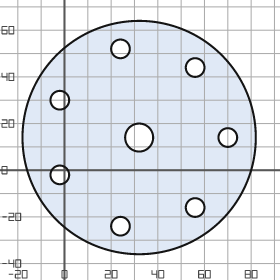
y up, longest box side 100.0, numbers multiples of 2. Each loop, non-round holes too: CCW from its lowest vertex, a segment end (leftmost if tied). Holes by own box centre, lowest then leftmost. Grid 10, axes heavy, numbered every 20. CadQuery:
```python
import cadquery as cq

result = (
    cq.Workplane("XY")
    .moveTo(32.0, 14.0)
    .circle(50.0)
    .moveTo(24.0, -24.0)
    .circle(4.0)
    .moveTo(56.0, -16.0)
    .circle(4.0)
    .moveTo(-2.0, -2.0)
    .circle(4.0)
    .moveTo(32.0, 14.0)
    .circle(6.0)
    .moveTo(70.0, 14.0)
    .circle(4.0)
    .moveTo(-2.0, 30.0)
    .circle(4.0)
    .moveTo(56.0, 44.0)
    .circle(4.0)
    .moveTo(24.0, 52.0)
    .circle(4.0)
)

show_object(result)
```